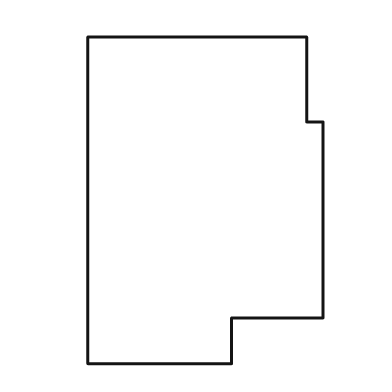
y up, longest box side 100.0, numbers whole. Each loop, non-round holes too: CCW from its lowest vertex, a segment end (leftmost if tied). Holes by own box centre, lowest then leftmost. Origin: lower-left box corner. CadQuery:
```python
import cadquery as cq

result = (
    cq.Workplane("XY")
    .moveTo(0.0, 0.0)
    .lineTo(44.0, 0.0)
    .lineTo(44.0, 14.0)
    .lineTo(72.0, 14.0)
    .lineTo(72.0, 74.0)
    .lineTo(67.0, 74.0)
    .lineTo(67.0, 100.0)
    .lineTo(0.0, 100.0)
    .close()
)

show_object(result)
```